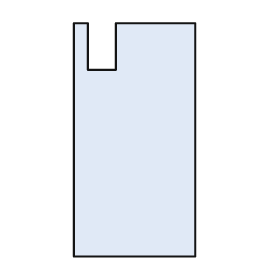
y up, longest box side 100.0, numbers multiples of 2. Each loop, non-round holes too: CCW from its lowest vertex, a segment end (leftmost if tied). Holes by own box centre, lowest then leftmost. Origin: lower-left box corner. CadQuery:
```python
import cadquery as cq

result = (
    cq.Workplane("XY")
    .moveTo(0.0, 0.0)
    .lineTo(52.0, 0.0)
    .lineTo(52.0, 100.0)
    .lineTo(18.0, 100.0)
    .lineTo(18.0, 80.0)
    .lineTo(6.0, 80.0)
    .lineTo(6.0, 100.0)
    .lineTo(0.0, 100.0)
    .close()
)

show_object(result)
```